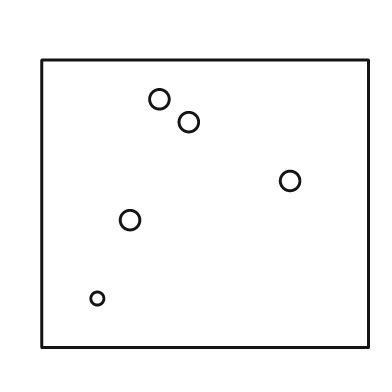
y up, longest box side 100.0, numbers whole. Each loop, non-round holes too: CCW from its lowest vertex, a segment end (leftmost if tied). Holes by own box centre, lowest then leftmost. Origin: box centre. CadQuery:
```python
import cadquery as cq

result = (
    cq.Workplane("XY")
    .moveTo(-50.0, -44.0)
    .lineTo(50.0, -44.0)
    .lineTo(50.0, 44.0)
    .lineTo(-50.0, 44.0)
    .close()
    .moveTo(-33.0, -29.0)
    .circle(2.0)
    .moveTo(-23.0, -5.0)
    .circle(3.0)
    .moveTo(26.0, 7.0)
    .circle(3.0)
    .moveTo(-5.0, 25.0)
    .circle(3.0)
    .moveTo(-14.0, 32.0)
    .circle(3.0)
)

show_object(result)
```